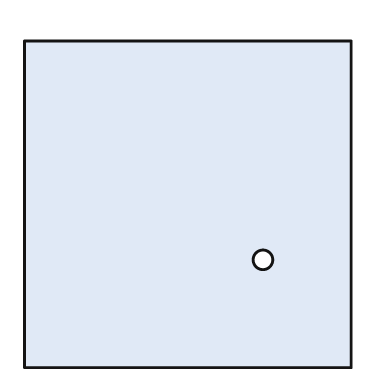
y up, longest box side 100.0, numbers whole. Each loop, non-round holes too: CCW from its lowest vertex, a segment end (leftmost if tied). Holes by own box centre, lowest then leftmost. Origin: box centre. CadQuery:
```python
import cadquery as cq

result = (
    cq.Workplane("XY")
    .moveTo(-50.0, -50.0)
    .lineTo(50.0, -50.0)
    .lineTo(50.0, 50.0)
    .lineTo(-50.0, 50.0)
    .close()
    .moveTo(23.0, -17.0)
    .circle(3.0)
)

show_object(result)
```